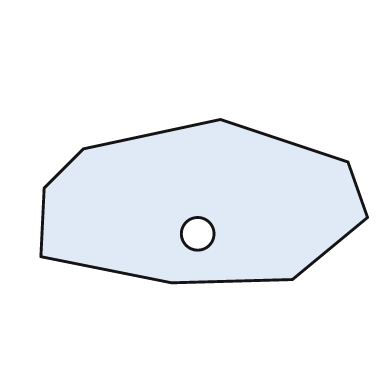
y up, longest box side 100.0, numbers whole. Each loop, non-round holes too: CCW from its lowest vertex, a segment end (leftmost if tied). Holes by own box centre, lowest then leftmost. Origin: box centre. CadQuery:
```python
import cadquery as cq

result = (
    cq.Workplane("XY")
    .moveTo(-10.0, -25.0)
    .lineTo(27.0, -24.0)
    .lineTo(50.0, -5.0)
    .lineTo(44.0, 12.0)
    .lineTo(5.0, 25.0)
    .lineTo(-37.0, 16.0)
    .lineTo(-49.0, 4.0)
    .lineTo(-50.0, -17.0)
    .close()
    .moveTo(-2.0, -10.0)
    .circle(5.0)
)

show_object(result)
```